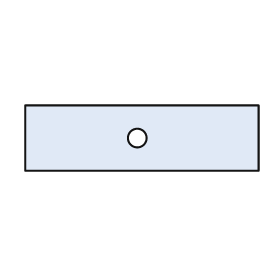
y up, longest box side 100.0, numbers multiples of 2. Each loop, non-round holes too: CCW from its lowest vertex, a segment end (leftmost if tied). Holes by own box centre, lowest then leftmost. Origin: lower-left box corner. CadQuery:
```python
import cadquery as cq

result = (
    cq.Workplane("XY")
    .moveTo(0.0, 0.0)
    .lineTo(100.0, 0.0)
    .lineTo(100.0, 28.0)
    .lineTo(0.0, 28.0)
    .close()
    .moveTo(48.0, 14.0)
    .circle(4.0)
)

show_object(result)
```